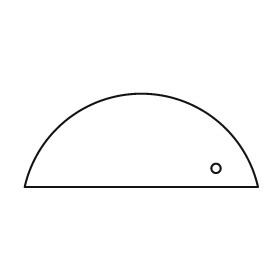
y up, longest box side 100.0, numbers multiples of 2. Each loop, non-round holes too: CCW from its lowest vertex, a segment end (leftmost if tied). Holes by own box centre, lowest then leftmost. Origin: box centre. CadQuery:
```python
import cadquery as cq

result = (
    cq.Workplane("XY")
    .moveTo(-50.0, -20.0)
    .lineTo(50.0, -20.0)
    .threePointArc((0.0, 20.0), (-50.0, -20.0))
    .close()
    .moveTo(32.0, -12.0)
    .circle(2.0)
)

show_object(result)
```